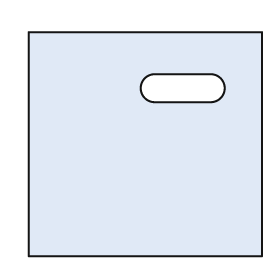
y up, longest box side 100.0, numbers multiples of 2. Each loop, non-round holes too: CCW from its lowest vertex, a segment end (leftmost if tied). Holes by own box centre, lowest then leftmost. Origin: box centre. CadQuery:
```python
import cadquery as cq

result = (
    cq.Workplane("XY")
    .moveTo(-50.0, -48.0)
    .lineTo(50.0, -48.0)
    .lineTo(50.0, 48.0)
    .lineTo(-50.0, 48.0)
    .close()
    .moveTo(4.0, 18.0)
    .lineTo(28.0, 18.0)
    .threePointArc((34.0, 24.0), (28.0, 30.0))
    .lineTo(4.0, 30.0)
    .threePointArc((-2.0, 24.0), (4.0, 18.0))
    .close()
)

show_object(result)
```